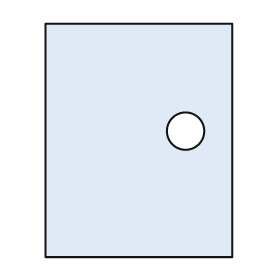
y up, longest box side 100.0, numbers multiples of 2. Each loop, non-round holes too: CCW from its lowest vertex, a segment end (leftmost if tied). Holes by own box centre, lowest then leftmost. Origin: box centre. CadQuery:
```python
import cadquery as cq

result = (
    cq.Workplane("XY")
    .moveTo(-40.0, -50.0)
    .lineTo(40.0, -50.0)
    .lineTo(40.0, 50.0)
    .lineTo(-40.0, 50.0)
    .close()
    .moveTo(20.0, 4.0)
    .circle(8.0)
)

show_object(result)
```